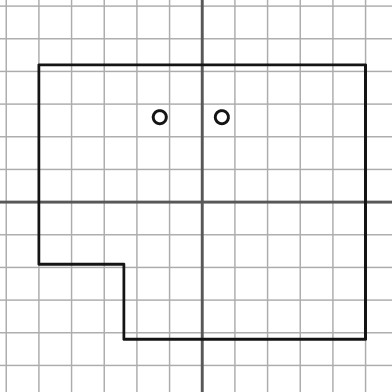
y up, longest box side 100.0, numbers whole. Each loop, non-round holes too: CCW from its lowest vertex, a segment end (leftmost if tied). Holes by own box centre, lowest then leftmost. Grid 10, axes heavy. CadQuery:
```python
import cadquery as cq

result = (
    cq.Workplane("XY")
    .moveTo(-24.0, -42.0)
    .lineTo(50.0, -42.0)
    .lineTo(50.0, 42.0)
    .lineTo(-50.0, 42.0)
    .lineTo(-50.0, -19.0)
    .lineTo(-24.0, -19.0)
    .close()
    .moveTo(-13.0, 26.0)
    .circle(2.0)
    .moveTo(6.0, 26.0)
    .circle(2.0)
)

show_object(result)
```